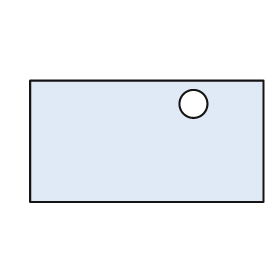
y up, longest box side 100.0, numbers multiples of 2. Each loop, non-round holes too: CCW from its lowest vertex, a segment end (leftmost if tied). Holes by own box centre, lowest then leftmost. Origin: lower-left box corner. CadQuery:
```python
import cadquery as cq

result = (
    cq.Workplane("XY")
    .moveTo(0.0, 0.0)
    .lineTo(100.0, 0.0)
    .lineTo(100.0, 52.0)
    .lineTo(0.0, 52.0)
    .close()
    .moveTo(70.0, 42.0)
    .circle(6.0)
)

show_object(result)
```